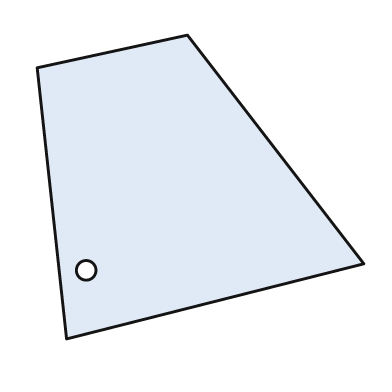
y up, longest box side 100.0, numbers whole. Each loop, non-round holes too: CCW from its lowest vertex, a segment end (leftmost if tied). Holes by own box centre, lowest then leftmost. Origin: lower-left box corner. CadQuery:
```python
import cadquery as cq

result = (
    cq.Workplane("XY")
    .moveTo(9.0, 0.0)
    .lineTo(100.0, 23.0)
    .lineTo(46.0, 93.0)
    .lineTo(0.0, 83.0)
    .close()
    .moveTo(15.0, 21.0)
    .circle(3.0)
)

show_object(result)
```